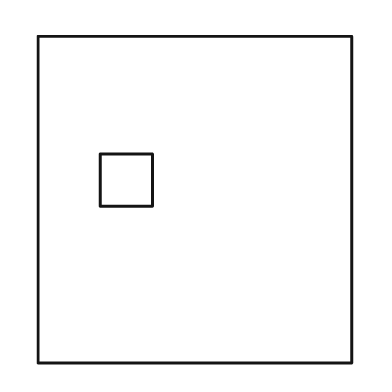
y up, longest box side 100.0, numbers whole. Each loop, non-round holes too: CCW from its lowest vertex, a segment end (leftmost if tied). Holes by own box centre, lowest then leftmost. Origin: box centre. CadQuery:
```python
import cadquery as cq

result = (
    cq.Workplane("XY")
    .moveTo(-48.0, -50.0)
    .lineTo(48.0, -50.0)
    .lineTo(48.0, 50.0)
    .lineTo(-48.0, 50.0)
    .close()
    .moveTo(-29.0, -2.0)
    .lineTo(-13.0, -2.0)
    .lineTo(-13.0, 14.0)
    .lineTo(-29.0, 14.0)
    .close()
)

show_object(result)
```